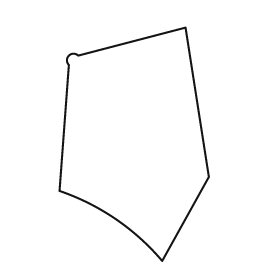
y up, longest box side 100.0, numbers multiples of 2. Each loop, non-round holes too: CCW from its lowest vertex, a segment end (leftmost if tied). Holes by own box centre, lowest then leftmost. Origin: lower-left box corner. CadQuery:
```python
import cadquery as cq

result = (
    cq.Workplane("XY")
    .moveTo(44.0, 0.0)
    .lineTo(64.0, 36.0)
    .lineTo(54.0, 100.0)
    .lineTo(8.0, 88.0)
    .threePointArc((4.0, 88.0), (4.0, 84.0))
    .lineTo(0.0, 30.0)
    .threePointArc((24.0, 18.0), (44.0, 0.0))
    .close()
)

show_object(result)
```